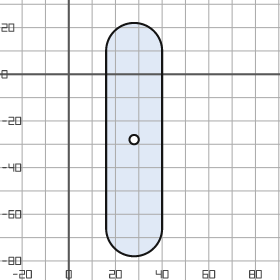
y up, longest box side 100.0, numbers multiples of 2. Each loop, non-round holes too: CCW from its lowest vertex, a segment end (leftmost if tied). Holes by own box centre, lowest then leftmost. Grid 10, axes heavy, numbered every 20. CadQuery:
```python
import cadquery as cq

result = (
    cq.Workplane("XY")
    .moveTo(16.0, -66.0)
    .threePointArc((28.0, -78.0), (40.0, -66.0))
    .lineTo(40.0, 10.0)
    .threePointArc((28.0, 22.0), (16.0, 10.0))
    .close()
    .moveTo(28.0, -28.0)
    .circle(2.0)
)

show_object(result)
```